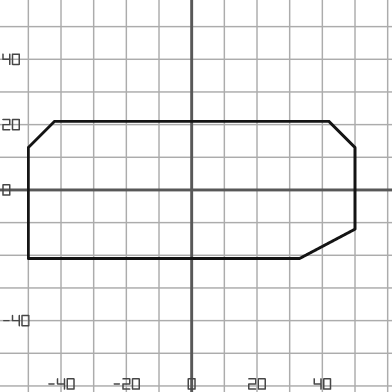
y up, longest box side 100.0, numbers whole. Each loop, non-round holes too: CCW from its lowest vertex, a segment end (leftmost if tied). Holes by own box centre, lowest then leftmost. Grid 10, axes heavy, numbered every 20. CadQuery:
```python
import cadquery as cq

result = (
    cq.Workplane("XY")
    .moveTo(-50.0, -21.0)
    .lineTo(33.0, -21.0)
    .lineTo(50.0, -12.0)
    .lineTo(50.0, 13.0)
    .lineTo(42.0, 21.0)
    .lineTo(-42.0, 21.0)
    .lineTo(-50.0, 13.0)
    .close()
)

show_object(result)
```